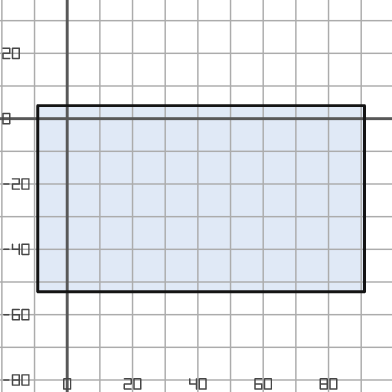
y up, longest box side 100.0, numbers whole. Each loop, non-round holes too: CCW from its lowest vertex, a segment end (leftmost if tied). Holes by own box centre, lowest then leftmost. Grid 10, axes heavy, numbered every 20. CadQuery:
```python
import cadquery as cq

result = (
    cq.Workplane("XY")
    .moveTo(-9.0, -53.0)
    .lineTo(91.0, -53.0)
    .lineTo(91.0, 4.0)
    .lineTo(-9.0, 4.0)
    .close()
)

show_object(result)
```